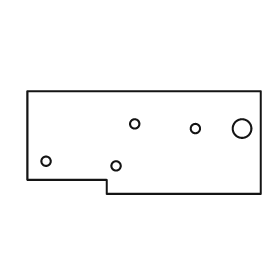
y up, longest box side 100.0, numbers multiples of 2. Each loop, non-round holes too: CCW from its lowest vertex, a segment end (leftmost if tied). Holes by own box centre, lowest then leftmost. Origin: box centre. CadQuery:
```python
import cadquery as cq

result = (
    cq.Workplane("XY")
    .moveTo(-16.0, -22.0)
    .lineTo(50.0, -22.0)
    .lineTo(50.0, 22.0)
    .lineTo(-50.0, 22.0)
    .lineTo(-50.0, -16.0)
    .lineTo(-16.0, -16.0)
    .close()
    .moveTo(-12.0, -10.0)
    .circle(2.0)
    .moveTo(-42.0, -8.0)
    .circle(2.0)
    .moveTo(22.0, 6.0)
    .circle(2.0)
    .moveTo(42.0, 6.0)
    .circle(4.0)
    .moveTo(-4.0, 8.0)
    .circle(2.0)
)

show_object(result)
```